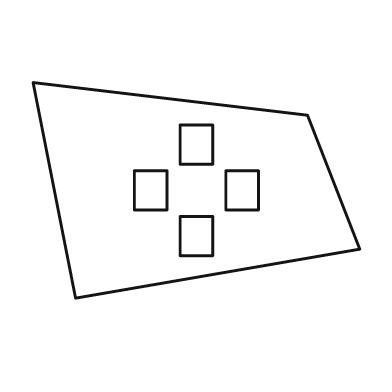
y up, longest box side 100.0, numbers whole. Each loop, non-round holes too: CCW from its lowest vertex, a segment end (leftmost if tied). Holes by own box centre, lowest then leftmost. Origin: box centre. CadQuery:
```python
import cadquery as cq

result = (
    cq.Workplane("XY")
    .moveTo(-37.0, -33.0)
    .lineTo(50.0, -18.0)
    .lineTo(34.0, 23.0)
    .lineTo(-50.0, 33.0)
    .close()
    .moveTo(-5.0, -20.0)
    .lineTo(5.0, -20.0)
    .lineTo(5.0, -8.0)
    .lineTo(-5.0, -8.0)
    .close()
    .moveTo(-19.0, -6.0)
    .lineTo(-9.0, -6.0)
    .lineTo(-9.0, 6.0)
    .lineTo(-19.0, 6.0)
    .close()
    .moveTo(9.0, -6.0)
    .lineTo(19.0, -6.0)
    .lineTo(19.0, 6.0)
    .lineTo(9.0, 6.0)
    .close()
    .moveTo(-5.0, 8.0)
    .lineTo(5.0, 8.0)
    .lineTo(5.0, 20.0)
    .lineTo(-5.0, 20.0)
    .close()
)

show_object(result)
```